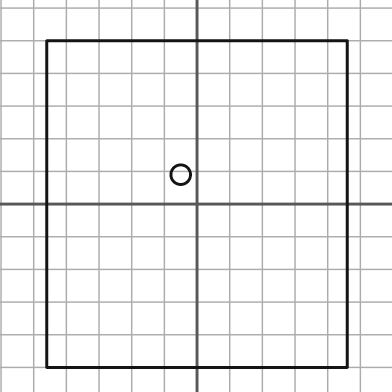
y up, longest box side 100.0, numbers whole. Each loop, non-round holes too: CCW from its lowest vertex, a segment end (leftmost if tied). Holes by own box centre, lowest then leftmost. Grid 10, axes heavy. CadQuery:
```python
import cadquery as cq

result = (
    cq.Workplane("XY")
    .moveTo(-46.0, -50.0)
    .lineTo(46.0, -50.0)
    .lineTo(46.0, 50.0)
    .lineTo(-46.0, 50.0)
    .close()
    .moveTo(-5.0, 9.0)
    .circle(3.0)
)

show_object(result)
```